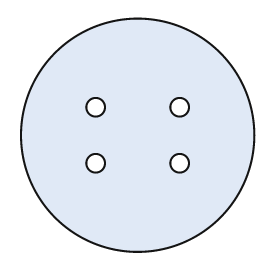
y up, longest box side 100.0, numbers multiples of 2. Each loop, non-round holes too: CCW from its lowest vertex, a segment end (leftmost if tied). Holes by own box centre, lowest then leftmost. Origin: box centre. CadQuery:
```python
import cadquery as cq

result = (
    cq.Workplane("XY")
    .moveTo(0.0, 0.0)
    .circle(50.0)
    .moveTo(-18.0, -12.0)
    .circle(4.0)
    .moveTo(18.0, -12.0)
    .circle(4.0)
    .moveTo(-18.0, 12.0)
    .circle(4.0)
    .moveTo(18.0, 12.0)
    .circle(4.0)
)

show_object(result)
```